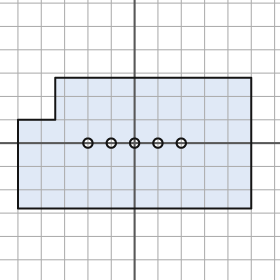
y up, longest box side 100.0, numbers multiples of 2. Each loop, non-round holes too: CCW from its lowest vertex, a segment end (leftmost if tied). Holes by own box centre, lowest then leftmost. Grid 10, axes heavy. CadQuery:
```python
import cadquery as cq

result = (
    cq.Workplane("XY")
    .moveTo(-50.0, -28.0)
    .lineTo(50.0, -28.0)
    .lineTo(50.0, 28.0)
    .lineTo(-34.0, 28.0)
    .lineTo(-34.0, 10.0)
    .lineTo(-50.0, 10.0)
    .close()
    .moveTo(-20.0, 0.0)
    .circle(2.0)
    .moveTo(-10.0, 0.0)
    .circle(2.0)
    .moveTo(0.0, 0.0)
    .circle(2.0)
    .moveTo(10.0, 0.0)
    .circle(2.0)
    .moveTo(20.0, 0.0)
    .circle(2.0)
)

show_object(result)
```